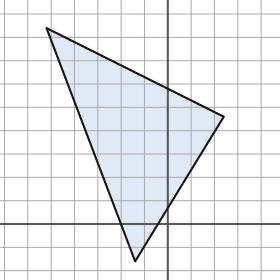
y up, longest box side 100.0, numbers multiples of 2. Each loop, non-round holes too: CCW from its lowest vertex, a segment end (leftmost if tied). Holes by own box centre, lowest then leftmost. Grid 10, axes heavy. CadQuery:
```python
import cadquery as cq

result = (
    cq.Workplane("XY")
    .moveTo(-14.0, -16.0)
    .lineTo(24.0, 46.0)
    .lineTo(-52.0, 84.0)
    .close()
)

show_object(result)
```